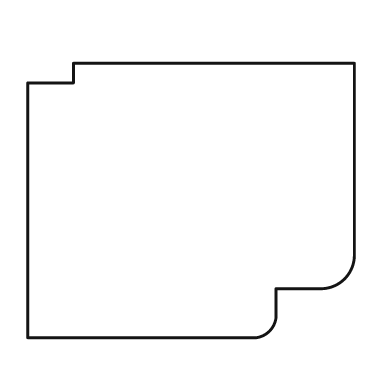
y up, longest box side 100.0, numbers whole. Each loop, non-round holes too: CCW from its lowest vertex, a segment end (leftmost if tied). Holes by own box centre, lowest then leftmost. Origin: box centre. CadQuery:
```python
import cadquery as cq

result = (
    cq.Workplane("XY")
    .moveTo(-50.0, -42.0)
    .lineTo(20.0, -42.0)
    .threePointArc((24.0, -40.0), (26.0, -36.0))
    .lineTo(26.0, -27.0)
    .lineTo(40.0, -27.0)
    .threePointArc((47.0, -24.0), (50.0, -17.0))
    .lineTo(50.0, 42.0)
    .lineTo(-36.0, 42.0)
    .lineTo(-36.0, 36.0)
    .lineTo(-50.0, 36.0)
    .close()
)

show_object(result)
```